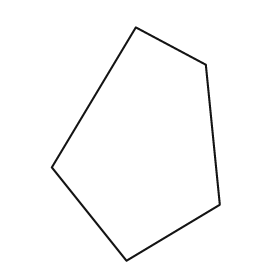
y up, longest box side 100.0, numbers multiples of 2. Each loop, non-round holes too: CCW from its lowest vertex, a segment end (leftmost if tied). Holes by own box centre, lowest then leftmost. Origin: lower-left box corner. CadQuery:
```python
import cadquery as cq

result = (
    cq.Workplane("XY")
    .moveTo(32.0, 0.0)
    .lineTo(72.0, 24.0)
    .lineTo(66.0, 84.0)
    .lineTo(36.0, 100.0)
    .lineTo(0.0, 40.0)
    .close()
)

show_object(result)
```